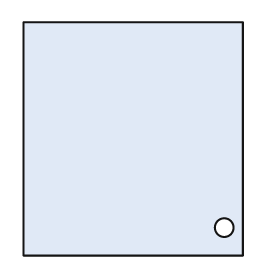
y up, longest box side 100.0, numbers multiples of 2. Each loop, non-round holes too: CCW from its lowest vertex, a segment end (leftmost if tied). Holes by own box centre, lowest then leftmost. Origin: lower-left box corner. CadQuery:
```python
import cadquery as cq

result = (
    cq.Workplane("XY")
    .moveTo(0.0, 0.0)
    .lineTo(94.0, 0.0)
    .lineTo(94.0, 100.0)
    .lineTo(0.0, 100.0)
    .close()
    .moveTo(86.0, 12.0)
    .circle(4.0)
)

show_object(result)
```